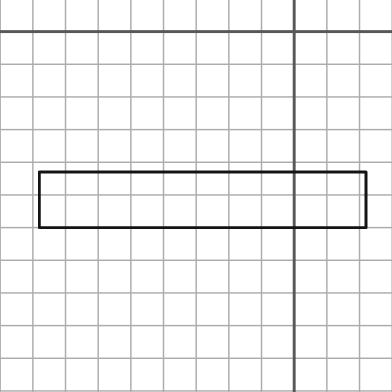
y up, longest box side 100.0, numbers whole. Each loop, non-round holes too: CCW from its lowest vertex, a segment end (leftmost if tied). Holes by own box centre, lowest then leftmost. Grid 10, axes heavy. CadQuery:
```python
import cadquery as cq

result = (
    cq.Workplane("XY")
    .moveTo(-78.0, -60.0)
    .lineTo(22.0, -60.0)
    .lineTo(22.0, -43.0)
    .lineTo(-78.0, -43.0)
    .close()
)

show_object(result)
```